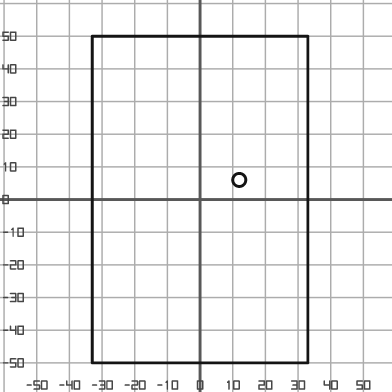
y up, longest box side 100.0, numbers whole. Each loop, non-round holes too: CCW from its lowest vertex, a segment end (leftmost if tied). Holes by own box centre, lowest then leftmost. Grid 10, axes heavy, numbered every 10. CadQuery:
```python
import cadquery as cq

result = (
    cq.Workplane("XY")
    .moveTo(-33.0, -50.0)
    .lineTo(33.0, -50.0)
    .lineTo(33.0, 50.0)
    .lineTo(-33.0, 50.0)
    .close()
    .moveTo(12.0, 6.0)
    .circle(2.0)
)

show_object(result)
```